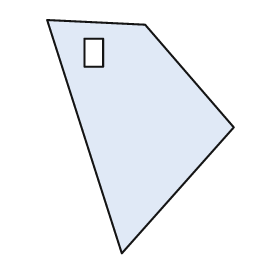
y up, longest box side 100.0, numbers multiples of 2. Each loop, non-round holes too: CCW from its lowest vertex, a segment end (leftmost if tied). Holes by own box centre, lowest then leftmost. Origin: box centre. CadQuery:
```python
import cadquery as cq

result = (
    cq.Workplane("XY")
    .moveTo(-8.0, -50.0)
    .lineTo(40.0, 4.0)
    .lineTo(2.0, 48.0)
    .lineTo(-40.0, 50.0)
    .close()
    .moveTo(-24.0, 30.0)
    .lineTo(-16.0, 30.0)
    .lineTo(-16.0, 42.0)
    .lineTo(-24.0, 42.0)
    .close()
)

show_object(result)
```